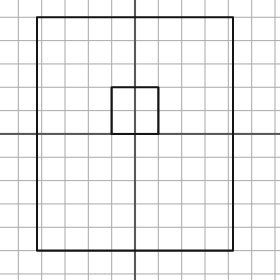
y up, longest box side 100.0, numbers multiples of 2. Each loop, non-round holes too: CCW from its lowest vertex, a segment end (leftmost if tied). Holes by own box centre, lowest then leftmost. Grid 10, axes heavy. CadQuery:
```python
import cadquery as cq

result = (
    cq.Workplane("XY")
    .moveTo(-42.0, -50.0)
    .lineTo(42.0, -50.0)
    .lineTo(42.0, 50.0)
    .lineTo(-42.0, 50.0)
    .close()
    .moveTo(-10.0, 0.0)
    .lineTo(10.0, 0.0)
    .lineTo(10.0, 20.0)
    .lineTo(-10.0, 20.0)
    .close()
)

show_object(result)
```